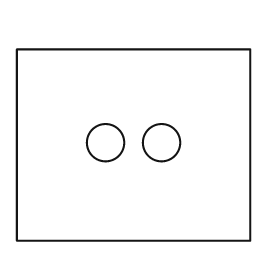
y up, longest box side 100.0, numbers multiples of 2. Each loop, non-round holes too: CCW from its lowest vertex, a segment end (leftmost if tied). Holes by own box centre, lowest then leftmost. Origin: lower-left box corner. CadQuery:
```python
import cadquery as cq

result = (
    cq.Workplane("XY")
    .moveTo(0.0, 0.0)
    .lineTo(100.0, 0.0)
    .lineTo(100.0, 82.0)
    .lineTo(0.0, 82.0)
    .close()
    .moveTo(38.0, 42.0)
    .circle(8.0)
    .moveTo(62.0, 42.0)
    .circle(8.0)
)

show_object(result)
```